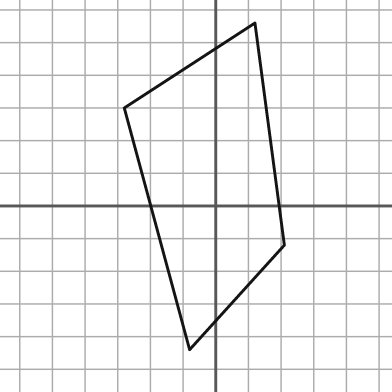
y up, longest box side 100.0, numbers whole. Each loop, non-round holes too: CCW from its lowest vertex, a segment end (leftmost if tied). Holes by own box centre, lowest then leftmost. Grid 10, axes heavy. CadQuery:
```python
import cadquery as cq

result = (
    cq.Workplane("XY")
    .moveTo(-8.0, -44.0)
    .lineTo(21.0, -12.0)
    .lineTo(12.0, 56.0)
    .lineTo(-28.0, 30.0)
    .close()
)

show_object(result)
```